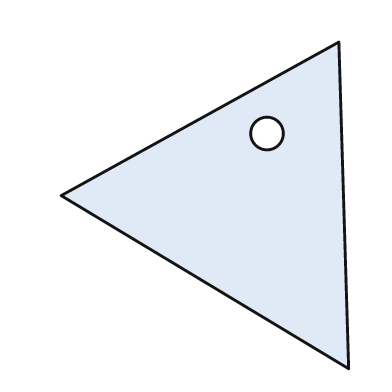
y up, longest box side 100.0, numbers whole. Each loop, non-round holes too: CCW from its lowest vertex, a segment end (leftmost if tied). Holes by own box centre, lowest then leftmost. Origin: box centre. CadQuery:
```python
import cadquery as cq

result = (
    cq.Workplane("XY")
    .moveTo(44.0, -50.0)
    .lineTo(41.0, 50.0)
    .lineTo(-44.0, 3.0)
    .close()
    .moveTo(19.0, 22.0)
    .circle(5.0)
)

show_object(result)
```